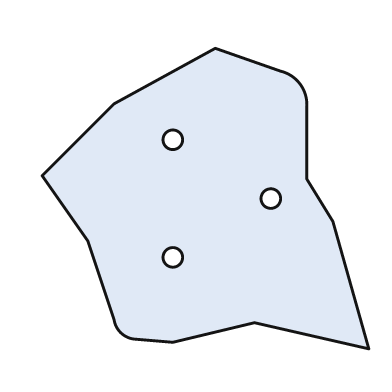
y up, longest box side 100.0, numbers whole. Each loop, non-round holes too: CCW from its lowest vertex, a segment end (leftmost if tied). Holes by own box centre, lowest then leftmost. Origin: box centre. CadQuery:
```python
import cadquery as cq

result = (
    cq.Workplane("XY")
    .moveTo(50.0, -46.0)
    .lineTo(39.0, -7.0)
    .lineTo(31.0, 6.0)
    .lineTo(31.0, 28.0)
    .threePointArc((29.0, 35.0), (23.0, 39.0))
    .lineTo(3.0, 46.0)
    .lineTo(-28.0, 29.0)
    .lineTo(-50.0, 7.0)
    .lineTo(-36.0, -13.0)
    .lineTo(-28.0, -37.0)
    .threePointArc((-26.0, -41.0), (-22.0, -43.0))
    .lineTo(-10.0, -44.0)
    .lineTo(15.0, -38.0)
    .close()
    .moveTo(-10.0, -18.0)
    .circle(3.0)
    .moveTo(20.0, 0.0)
    .circle(3.0)
    .moveTo(-10.0, 18.0)
    .circle(3.0)
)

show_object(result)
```